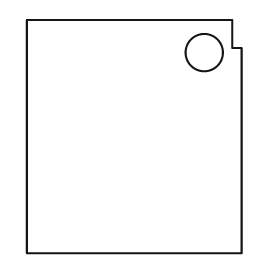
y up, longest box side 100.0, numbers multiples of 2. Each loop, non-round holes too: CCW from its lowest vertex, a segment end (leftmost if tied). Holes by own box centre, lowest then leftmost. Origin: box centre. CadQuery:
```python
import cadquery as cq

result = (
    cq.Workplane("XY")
    .moveTo(-46.0, -50.0)
    .lineTo(46.0, -50.0)
    .lineTo(46.0, 38.0)
    .lineTo(42.0, 38.0)
    .lineTo(42.0, 50.0)
    .lineTo(-46.0, 50.0)
    .close()
    .moveTo(30.0, 36.0)
    .circle(8.0)
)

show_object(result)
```